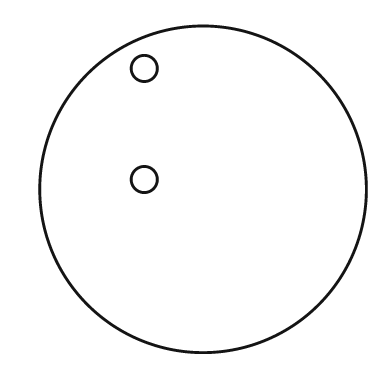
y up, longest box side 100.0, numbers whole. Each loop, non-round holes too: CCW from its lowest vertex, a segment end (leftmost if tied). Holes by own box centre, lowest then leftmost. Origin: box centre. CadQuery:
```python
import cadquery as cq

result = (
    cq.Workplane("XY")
    .moveTo(0.0, 0.0)
    .circle(50.0)
    .moveTo(-18.0, 3.0)
    .circle(4.0)
    .moveTo(-18.0, 37.0)
    .circle(4.0)
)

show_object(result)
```